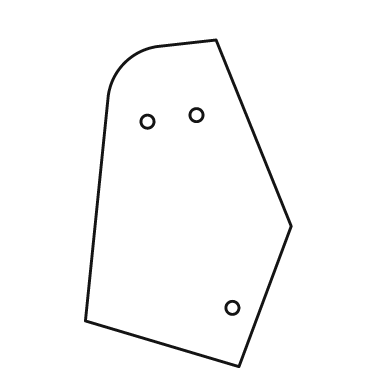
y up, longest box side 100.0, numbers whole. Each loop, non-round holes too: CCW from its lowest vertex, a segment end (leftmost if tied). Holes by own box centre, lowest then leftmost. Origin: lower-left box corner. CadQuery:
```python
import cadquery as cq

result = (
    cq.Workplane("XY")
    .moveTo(47.0, 0.0)
    .lineTo(63.0, 43.0)
    .lineTo(40.0, 100.0)
    .lineTo(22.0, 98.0)
    .threePointArc((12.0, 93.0), (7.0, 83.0))
    .lineTo(0.0, 14.0)
    .close()
    .moveTo(45.0, 18.0)
    .circle(2.0)
    .moveTo(19.0, 75.0)
    .circle(2.0)
    .moveTo(34.0, 77.0)
    .circle(2.0)
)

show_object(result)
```